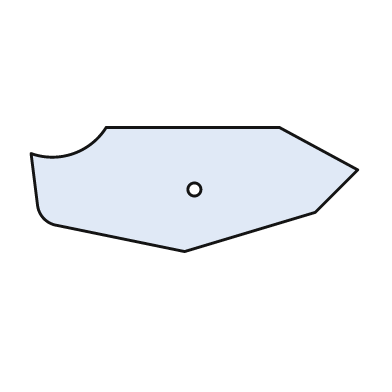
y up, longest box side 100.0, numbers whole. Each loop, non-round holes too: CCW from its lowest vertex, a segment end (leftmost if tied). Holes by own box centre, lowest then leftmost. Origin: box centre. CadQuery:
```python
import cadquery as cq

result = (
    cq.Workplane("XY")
    .moveTo(-3.0, -19.0)
    .lineTo(37.0, -7.0)
    .lineTo(50.0, 6.0)
    .lineTo(26.0, 19.0)
    .lineTo(-27.0, 19.0)
    .threePointArc((-37.0, 11.0), (-50.0, 11.0))
    .lineTo(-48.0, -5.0)
    .threePointArc((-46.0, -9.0), (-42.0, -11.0))
    .close()
    .moveTo(0.0, 0.0)
    .circle(2.0)
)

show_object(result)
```